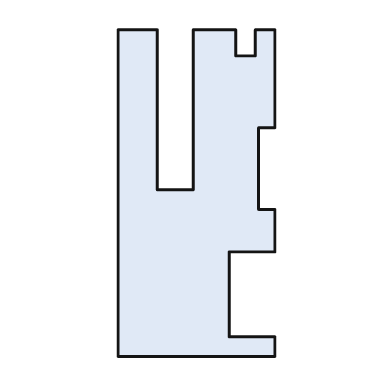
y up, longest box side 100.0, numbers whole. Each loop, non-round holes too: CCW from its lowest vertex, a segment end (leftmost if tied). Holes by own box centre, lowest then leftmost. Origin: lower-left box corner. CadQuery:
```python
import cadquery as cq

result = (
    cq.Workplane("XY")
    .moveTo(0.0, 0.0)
    .lineTo(48.0, 0.0)
    .lineTo(48.0, 6.0)
    .lineTo(34.0, 6.0)
    .lineTo(34.0, 32.0)
    .lineTo(48.0, 32.0)
    .lineTo(48.0, 45.0)
    .lineTo(43.0, 45.0)
    .lineTo(43.0, 70.0)
    .lineTo(48.0, 70.0)
    .lineTo(48.0, 100.0)
    .lineTo(42.0, 100.0)
    .lineTo(42.0, 92.0)
    .lineTo(36.0, 92.0)
    .lineTo(36.0, 100.0)
    .lineTo(23.0, 100.0)
    .lineTo(23.0, 51.0)
    .lineTo(12.0, 51.0)
    .lineTo(12.0, 100.0)
    .lineTo(0.0, 100.0)
    .close()
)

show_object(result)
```